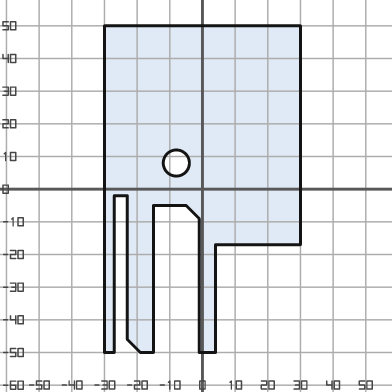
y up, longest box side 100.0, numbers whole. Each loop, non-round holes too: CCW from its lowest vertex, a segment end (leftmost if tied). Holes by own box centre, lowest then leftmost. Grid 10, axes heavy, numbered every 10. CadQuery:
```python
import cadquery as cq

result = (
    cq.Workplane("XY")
    .moveTo(-30.0, -50.0)
    .lineTo(-27.0, -50.0)
    .lineTo(-27.0, -2.0)
    .lineTo(-23.0, -2.0)
    .lineTo(-23.0, -46.0)
    .lineTo(-19.0, -50.0)
    .lineTo(-15.0, -50.0)
    .lineTo(-15.0, -5.0)
    .lineTo(-5.0, -5.0)
    .lineTo(-1.0, -9.0)
    .lineTo(-1.0, -50.0)
    .lineTo(4.0, -50.0)
    .lineTo(4.0, -17.0)
    .lineTo(30.0, -17.0)
    .lineTo(30.0, 50.0)
    .lineTo(-30.0, 50.0)
    .close()
    .moveTo(-8.0, 8.0)
    .circle(4.0)
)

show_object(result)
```